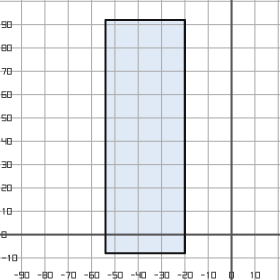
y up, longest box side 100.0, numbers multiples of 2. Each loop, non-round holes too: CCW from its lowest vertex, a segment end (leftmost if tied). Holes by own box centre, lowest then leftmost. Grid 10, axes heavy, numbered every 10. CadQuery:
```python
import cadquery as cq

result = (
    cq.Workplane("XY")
    .moveTo(-54.0, -8.0)
    .lineTo(-20.0, -8.0)
    .lineTo(-20.0, 92.0)
    .lineTo(-54.0, 92.0)
    .close()
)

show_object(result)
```